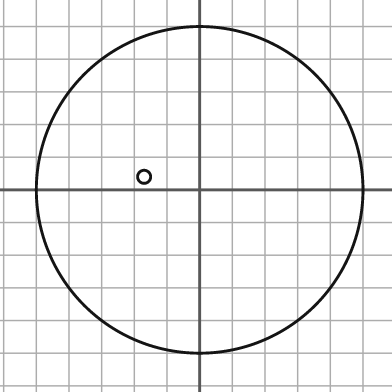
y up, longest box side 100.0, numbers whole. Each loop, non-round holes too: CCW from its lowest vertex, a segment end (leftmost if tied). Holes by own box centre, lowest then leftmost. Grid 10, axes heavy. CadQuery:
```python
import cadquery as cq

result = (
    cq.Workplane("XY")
    .moveTo(0.0, 0.0)
    .circle(50.0)
    .moveTo(-17.0, 4.0)
    .circle(2.0)
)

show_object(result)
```